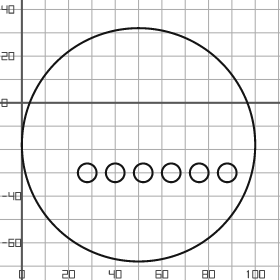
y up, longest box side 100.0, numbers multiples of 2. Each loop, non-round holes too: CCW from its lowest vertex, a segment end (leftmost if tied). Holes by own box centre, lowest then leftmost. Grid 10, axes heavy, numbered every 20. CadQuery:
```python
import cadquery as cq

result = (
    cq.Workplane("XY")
    .moveTo(50.0, -18.0)
    .circle(50.0)
    .moveTo(28.0, -30.0)
    .circle(4.0)
    .moveTo(40.0, -30.0)
    .circle(4.0)
    .moveTo(52.0, -30.0)
    .circle(4.0)
    .moveTo(64.0, -30.0)
    .circle(4.0)
    .moveTo(76.0, -30.0)
    .circle(4.0)
    .moveTo(88.0, -30.0)
    .circle(4.0)
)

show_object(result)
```